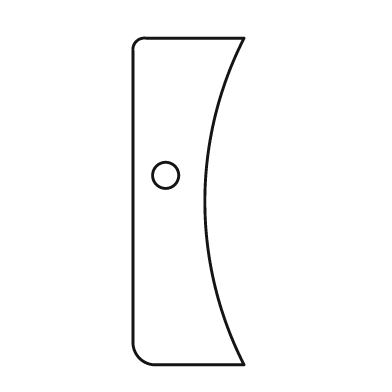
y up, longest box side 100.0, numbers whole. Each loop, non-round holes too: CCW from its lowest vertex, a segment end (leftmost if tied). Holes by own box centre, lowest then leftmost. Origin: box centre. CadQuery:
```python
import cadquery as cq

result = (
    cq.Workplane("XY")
    .moveTo(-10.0, -50.0)
    .lineTo(17.0, -50.0)
    .threePointArc((5.0, 0.0), (17.0, 50.0))
    .lineTo(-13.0, 50.0)
    .threePointArc((-16.0, 49.0), (-17.0, 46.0))
    .lineTo(-17.0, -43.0)
    .threePointArc((-15.0, -48.0), (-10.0, -50.0))
    .close()
    .moveTo(-7.0, 8.0)
    .circle(4.0)
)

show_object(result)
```